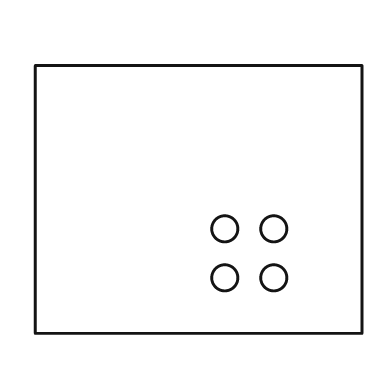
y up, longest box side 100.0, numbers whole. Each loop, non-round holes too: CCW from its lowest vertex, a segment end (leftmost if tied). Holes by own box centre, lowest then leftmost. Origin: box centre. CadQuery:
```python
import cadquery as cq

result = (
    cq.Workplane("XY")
    .moveTo(-50.0, -41.0)
    .lineTo(50.0, -41.0)
    .lineTo(50.0, 41.0)
    .lineTo(-50.0, 41.0)
    .close()
    .moveTo(8.0, -24.0)
    .circle(4.0)
    .moveTo(23.0, -24.0)
    .circle(4.0)
    .moveTo(8.0, -9.0)
    .circle(4.0)
    .moveTo(23.0, -9.0)
    .circle(4.0)
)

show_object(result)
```